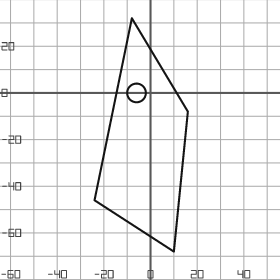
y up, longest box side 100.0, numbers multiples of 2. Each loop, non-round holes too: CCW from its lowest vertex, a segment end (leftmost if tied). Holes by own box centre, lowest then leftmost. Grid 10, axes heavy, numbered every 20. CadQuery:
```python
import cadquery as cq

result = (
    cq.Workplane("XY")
    .moveTo(10.0, -68.0)
    .lineTo(16.0, -8.0)
    .lineTo(-8.0, 32.0)
    .lineTo(-24.0, -46.0)
    .close()
    .moveTo(-6.0, 0.0)
    .circle(4.0)
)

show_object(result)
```